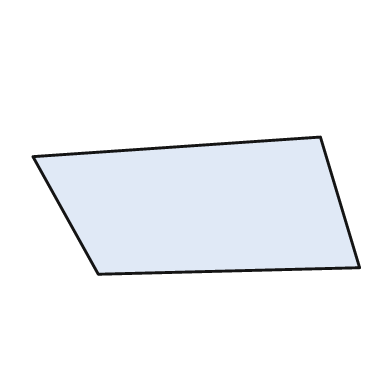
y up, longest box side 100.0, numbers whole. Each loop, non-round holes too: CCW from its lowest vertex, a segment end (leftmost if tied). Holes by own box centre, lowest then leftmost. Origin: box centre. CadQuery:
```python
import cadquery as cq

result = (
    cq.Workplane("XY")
    .moveTo(-30.0, -21.0)
    .lineTo(50.0, -19.0)
    .lineTo(38.0, 21.0)
    .lineTo(-50.0, 15.0)
    .close()
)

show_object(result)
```